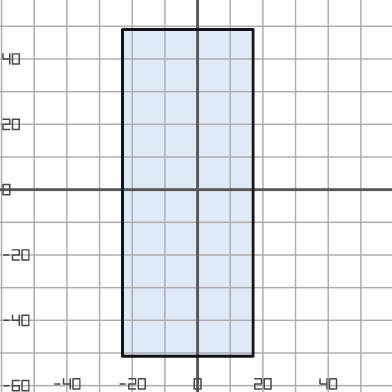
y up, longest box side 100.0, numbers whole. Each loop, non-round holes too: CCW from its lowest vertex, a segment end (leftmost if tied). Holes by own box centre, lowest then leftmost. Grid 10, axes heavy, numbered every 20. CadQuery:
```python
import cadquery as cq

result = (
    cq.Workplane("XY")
    .moveTo(-23.0, -51.0)
    .lineTo(17.0, -51.0)
    .lineTo(17.0, 49.0)
    .lineTo(-23.0, 49.0)
    .close()
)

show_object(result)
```